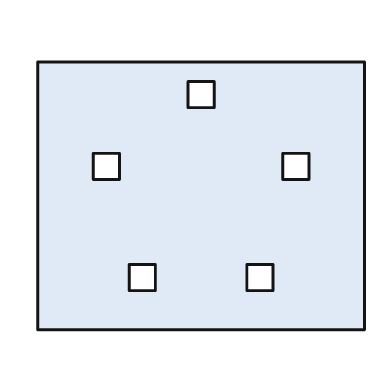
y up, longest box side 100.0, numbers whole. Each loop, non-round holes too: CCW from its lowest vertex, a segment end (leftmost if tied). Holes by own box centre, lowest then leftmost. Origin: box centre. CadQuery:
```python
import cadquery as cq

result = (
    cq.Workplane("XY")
    .moveTo(-50.0, -41.0)
    .lineTo(50.0, -41.0)
    .lineTo(50.0, 41.0)
    .lineTo(-50.0, 41.0)
    .close()
    .moveTo(-22.0, -29.0)
    .lineTo(-14.0, -29.0)
    .lineTo(-14.0, -21.0)
    .lineTo(-22.0, -21.0)
    .close()
    .moveTo(14.0, -29.0)
    .lineTo(22.0, -29.0)
    .lineTo(22.0, -21.0)
    .lineTo(14.0, -21.0)
    .close()
    .moveTo(-33.0, 5.0)
    .lineTo(-25.0, 5.0)
    .lineTo(-25.0, 13.0)
    .lineTo(-33.0, 13.0)
    .close()
    .moveTo(25.0, 5.0)
    .lineTo(33.0, 5.0)
    .lineTo(33.0, 13.0)
    .lineTo(25.0, 13.0)
    .close()
    .moveTo(-4.0, 27.0)
    .lineTo(4.0, 27.0)
    .lineTo(4.0, 35.0)
    .lineTo(-4.0, 35.0)
    .close()
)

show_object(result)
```